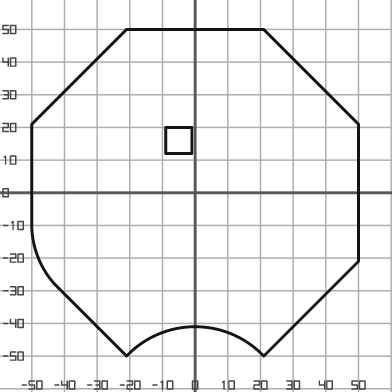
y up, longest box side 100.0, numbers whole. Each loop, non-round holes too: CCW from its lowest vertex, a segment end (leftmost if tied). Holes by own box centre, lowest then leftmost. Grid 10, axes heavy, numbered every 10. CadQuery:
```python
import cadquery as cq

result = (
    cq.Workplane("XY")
    .moveTo(-21.0, -50.0)
    .threePointArc((0.0, -41.0), (21.0, -50.0))
    .lineTo(50.0, -21.0)
    .lineTo(50.0, 21.0)
    .lineTo(21.0, 50.0)
    .lineTo(-21.0, 50.0)
    .lineTo(-50.0, 21.0)
    .lineTo(-50.0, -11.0)
    .threePointArc((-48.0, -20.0), (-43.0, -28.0))
    .close()
    .moveTo(-9.0, 12.0)
    .lineTo(-1.0, 12.0)
    .lineTo(-1.0, 20.0)
    .lineTo(-9.0, 20.0)
    .close()
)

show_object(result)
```